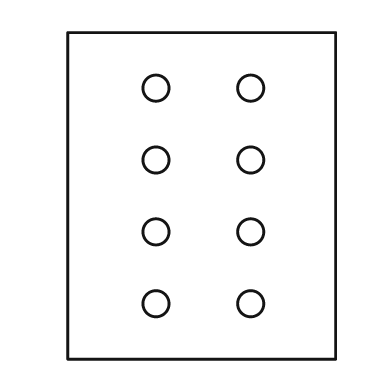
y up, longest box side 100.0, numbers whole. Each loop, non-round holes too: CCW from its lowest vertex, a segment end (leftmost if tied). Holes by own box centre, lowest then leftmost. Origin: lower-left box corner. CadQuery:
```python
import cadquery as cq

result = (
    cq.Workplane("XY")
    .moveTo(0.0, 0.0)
    .lineTo(82.0, 0.0)
    .lineTo(82.0, 100.0)
    .lineTo(0.0, 100.0)
    .close()
    .moveTo(27.0, 17.0)
    .circle(4.0)
    .moveTo(56.0, 17.0)
    .circle(4.0)
    .moveTo(27.0, 39.0)
    .circle(4.0)
    .moveTo(56.0, 39.0)
    .circle(4.0)
    .moveTo(27.0, 61.0)
    .circle(4.0)
    .moveTo(56.0, 61.0)
    .circle(4.0)
    .moveTo(27.0, 83.0)
    .circle(4.0)
    .moveTo(56.0, 83.0)
    .circle(4.0)
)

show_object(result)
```